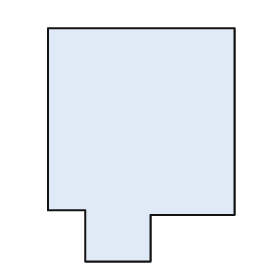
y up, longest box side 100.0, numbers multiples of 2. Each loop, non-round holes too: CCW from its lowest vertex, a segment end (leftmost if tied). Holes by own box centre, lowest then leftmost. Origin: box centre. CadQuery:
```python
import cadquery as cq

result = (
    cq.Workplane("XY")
    .moveTo(-24.0, -50.0)
    .lineTo(4.0, -50.0)
    .lineTo(4.0, -30.0)
    .lineTo(40.0, -30.0)
    .lineTo(40.0, 50.0)
    .lineTo(-40.0, 50.0)
    .lineTo(-40.0, -28.0)
    .lineTo(-24.0, -28.0)
    .close()
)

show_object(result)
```